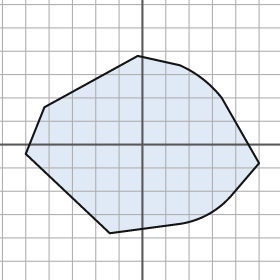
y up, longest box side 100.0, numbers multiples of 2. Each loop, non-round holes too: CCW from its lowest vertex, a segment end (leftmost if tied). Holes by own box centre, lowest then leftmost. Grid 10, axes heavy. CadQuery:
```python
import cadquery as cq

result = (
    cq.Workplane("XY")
    .moveTo(-14.0, -38.0)
    .lineTo(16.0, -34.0)
    .threePointArc((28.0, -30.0), (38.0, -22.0))
    .lineTo(50.0, -8.0)
    .lineTo(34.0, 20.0)
    .threePointArc((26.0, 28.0), (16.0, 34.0))
    .lineTo(-2.0, 38.0)
    .lineTo(-42.0, 16.0)
    .lineTo(-50.0, -4.0)
    .close()
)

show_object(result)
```